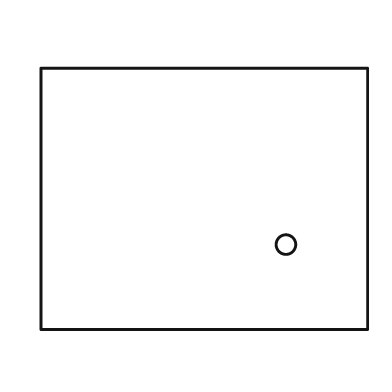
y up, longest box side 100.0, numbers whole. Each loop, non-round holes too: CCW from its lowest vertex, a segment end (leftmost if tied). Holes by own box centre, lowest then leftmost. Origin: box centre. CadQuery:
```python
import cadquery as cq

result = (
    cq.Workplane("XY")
    .moveTo(-50.0, -40.0)
    .lineTo(50.0, -40.0)
    .lineTo(50.0, 40.0)
    .lineTo(-50.0, 40.0)
    .close()
    .moveTo(25.0, -14.0)
    .circle(3.0)
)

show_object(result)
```